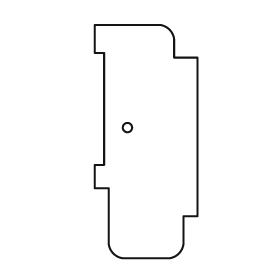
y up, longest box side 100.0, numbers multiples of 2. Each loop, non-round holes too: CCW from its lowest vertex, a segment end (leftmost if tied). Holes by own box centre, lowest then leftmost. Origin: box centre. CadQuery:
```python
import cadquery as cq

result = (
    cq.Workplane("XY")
    .moveTo(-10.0, -50.0)
    .lineTo(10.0, -50.0)
    .threePointArc((14.0, -48.0), (16.0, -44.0))
    .lineTo(16.0, -32.0)
    .lineTo(22.0, -32.0)
    .lineTo(22.0, 36.0)
    .lineTo(12.0, 36.0)
    .lineTo(12.0, 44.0)
    .threePointArc((10.0, 48.0), (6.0, 50.0))
    .lineTo(-22.0, 50.0)
    .lineTo(-22.0, 38.0)
    .lineTo(-18.0, 38.0)
    .lineTo(-18.0, -10.0)
    .lineTo(-22.0, -10.0)
    .lineTo(-22.0, -20.0)
    .lineTo(-16.0, -20.0)
    .lineTo(-16.0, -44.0)
    .threePointArc((-14.0, -48.0), (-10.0, -50.0))
    .close()
    .moveTo(-8.0, 6.0)
    .circle(2.0)
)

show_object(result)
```